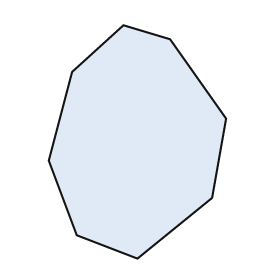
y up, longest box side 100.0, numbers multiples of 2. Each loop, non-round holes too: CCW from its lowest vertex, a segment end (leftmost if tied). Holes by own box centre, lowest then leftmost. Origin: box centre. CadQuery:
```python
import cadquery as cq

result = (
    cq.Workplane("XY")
    .moveTo(0.0, -50.0)
    .lineTo(32.0, -24.0)
    .lineTo(38.0, 10.0)
    .lineTo(14.0, 44.0)
    .lineTo(-6.0, 50.0)
    .lineTo(-28.0, 30.0)
    .lineTo(-38.0, -8.0)
    .lineTo(-26.0, -40.0)
    .close()
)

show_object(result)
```